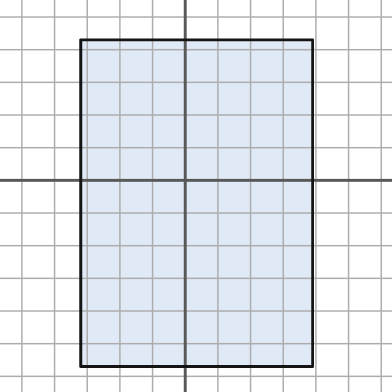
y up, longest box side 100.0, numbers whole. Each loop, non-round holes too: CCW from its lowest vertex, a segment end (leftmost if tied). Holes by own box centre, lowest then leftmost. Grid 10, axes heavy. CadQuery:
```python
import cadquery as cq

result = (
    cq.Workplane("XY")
    .moveTo(-32.0, -57.0)
    .lineTo(39.0, -57.0)
    .lineTo(39.0, 43.0)
    .lineTo(-32.0, 43.0)
    .close()
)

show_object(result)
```